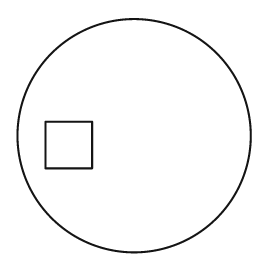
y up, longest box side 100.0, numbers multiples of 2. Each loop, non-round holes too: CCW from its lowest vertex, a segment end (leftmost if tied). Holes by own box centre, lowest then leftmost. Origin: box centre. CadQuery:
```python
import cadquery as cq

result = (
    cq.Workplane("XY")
    .moveTo(0.0, 0.0)
    .circle(50.0)
    .moveTo(-38.0, -14.0)
    .lineTo(-18.0, -14.0)
    .lineTo(-18.0, 6.0)
    .lineTo(-38.0, 6.0)
    .close()
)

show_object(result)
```